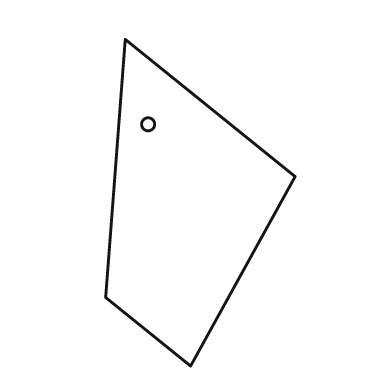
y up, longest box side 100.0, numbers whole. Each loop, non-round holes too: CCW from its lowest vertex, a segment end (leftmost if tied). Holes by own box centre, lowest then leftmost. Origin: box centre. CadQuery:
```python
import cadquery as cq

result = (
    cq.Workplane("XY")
    .moveTo(-3.0, -50.0)
    .lineTo(29.0, 8.0)
    .lineTo(-23.0, 50.0)
    .lineTo(-29.0, -29.0)
    .close()
    .moveTo(-16.0, 24.0)
    .circle(2.0)
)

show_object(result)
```